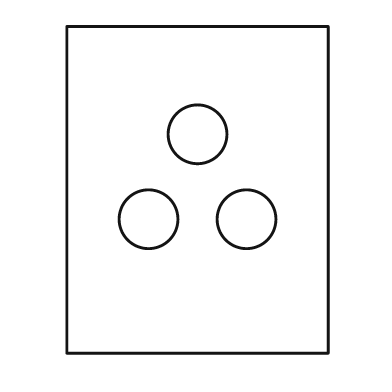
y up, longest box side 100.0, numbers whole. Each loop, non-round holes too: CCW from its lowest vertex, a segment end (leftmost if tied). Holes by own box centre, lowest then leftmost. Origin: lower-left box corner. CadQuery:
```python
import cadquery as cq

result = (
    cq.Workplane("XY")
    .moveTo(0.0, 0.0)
    .lineTo(80.0, 0.0)
    .lineTo(80.0, 100.0)
    .lineTo(0.0, 100.0)
    .close()
    .moveTo(25.0, 41.0)
    .circle(9.0)
    .moveTo(55.0, 41.0)
    .circle(9.0)
    .moveTo(40.0, 67.0)
    .circle(9.0)
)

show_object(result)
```